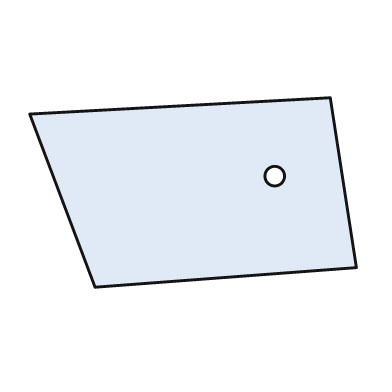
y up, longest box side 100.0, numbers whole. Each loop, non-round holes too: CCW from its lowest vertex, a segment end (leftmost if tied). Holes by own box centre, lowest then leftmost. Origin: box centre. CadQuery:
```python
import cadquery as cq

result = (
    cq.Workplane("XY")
    .moveTo(-30.0, -29.0)
    .lineTo(50.0, -23.0)
    .lineTo(42.0, 29.0)
    .lineTo(-50.0, 24.0)
    .close()
    .moveTo(25.0, 5.0)
    .circle(3.0)
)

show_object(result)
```